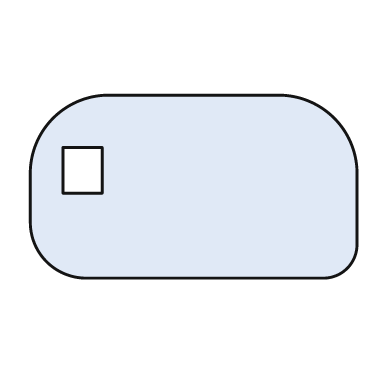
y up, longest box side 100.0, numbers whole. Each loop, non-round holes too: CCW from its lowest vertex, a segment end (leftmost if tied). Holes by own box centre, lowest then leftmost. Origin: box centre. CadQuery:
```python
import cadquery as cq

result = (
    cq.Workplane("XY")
    .moveTo(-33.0, -28.0)
    .lineTo(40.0, -28.0)
    .threePointArc((47.0, -25.0), (50.0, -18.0))
    .lineTo(50.0, 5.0)
    .threePointArc((43.0, 21.0), (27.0, 28.0))
    .lineTo(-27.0, 28.0)
    .threePointArc((-43.0, 21.0), (-50.0, 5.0))
    .lineTo(-50.0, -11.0)
    .threePointArc((-45.0, -23.0), (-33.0, -28.0))
    .close()
    .moveTo(-40.0, -2.0)
    .lineTo(-28.0, -2.0)
    .lineTo(-28.0, 12.0)
    .lineTo(-40.0, 12.0)
    .close()
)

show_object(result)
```